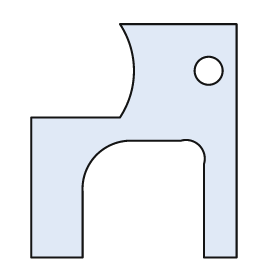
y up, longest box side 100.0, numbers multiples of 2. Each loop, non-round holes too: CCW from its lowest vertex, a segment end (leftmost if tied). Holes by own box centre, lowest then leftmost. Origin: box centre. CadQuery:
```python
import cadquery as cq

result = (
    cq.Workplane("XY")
    .moveTo(-44.0, -50.0)
    .lineTo(-22.0, -50.0)
    .lineTo(-22.0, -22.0)
    .threePointArc((-16.0, -6.0), (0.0, 0.0))
    .lineTo(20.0, 0.0)
    .threePointArc((28.0, -2.0), (30.0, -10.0))
    .lineTo(30.0, -50.0)
    .lineTo(44.0, -50.0)
    .lineTo(44.0, 50.0)
    .lineTo(-6.0, 50.0)
    .threePointArc((0.0, 30.0), (-6.0, 10.0))
    .lineTo(-44.0, 10.0)
    .close()
    .moveTo(32.0, 30.0)
    .circle(6.0)
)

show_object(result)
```